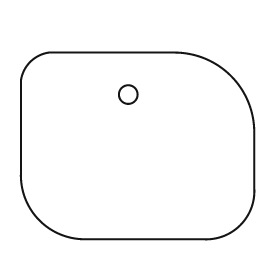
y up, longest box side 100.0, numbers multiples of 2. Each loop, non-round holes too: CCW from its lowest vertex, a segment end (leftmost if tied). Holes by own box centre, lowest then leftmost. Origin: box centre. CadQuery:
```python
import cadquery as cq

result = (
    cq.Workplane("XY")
    .moveTo(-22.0, -40.0)
    .lineTo(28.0, -40.0)
    .threePointArc((44.0, -34.0), (50.0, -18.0))
    .lineTo(50.0, 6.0)
    .threePointArc((40.0, 30.0), (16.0, 40.0))
    .lineTo(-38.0, 40.0)
    .threePointArc((-46.0, 36.0), (-50.0, 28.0))
    .lineTo(-50.0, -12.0)
    .threePointArc((-42.0, -32.0), (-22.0, -40.0))
    .close()
    .moveTo(-4.0, 22.0)
    .circle(4.0)
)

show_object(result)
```